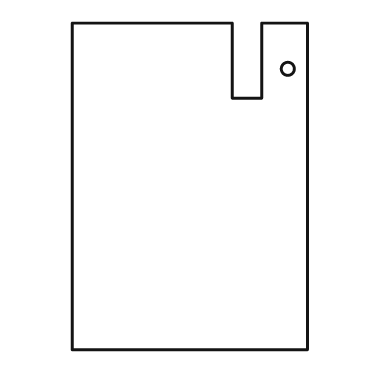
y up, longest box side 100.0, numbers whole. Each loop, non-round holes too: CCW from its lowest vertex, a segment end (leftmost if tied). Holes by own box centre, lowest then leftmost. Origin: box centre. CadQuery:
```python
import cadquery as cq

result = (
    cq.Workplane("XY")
    .moveTo(-36.0, -50.0)
    .lineTo(36.0, -50.0)
    .lineTo(36.0, 50.0)
    .lineTo(22.0, 50.0)
    .lineTo(22.0, 27.0)
    .lineTo(13.0, 27.0)
    .lineTo(13.0, 50.0)
    .lineTo(-36.0, 50.0)
    .close()
    .moveTo(30.0, 36.0)
    .circle(2.0)
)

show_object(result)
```